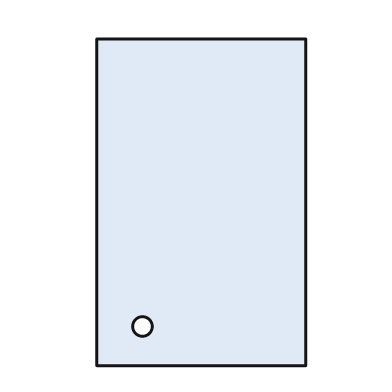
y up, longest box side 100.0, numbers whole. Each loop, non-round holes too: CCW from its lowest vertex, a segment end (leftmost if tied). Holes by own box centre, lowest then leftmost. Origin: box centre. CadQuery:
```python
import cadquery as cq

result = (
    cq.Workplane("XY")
    .moveTo(-32.0, -50.0)
    .lineTo(32.0, -50.0)
    .lineTo(32.0, 50.0)
    .lineTo(-32.0, 50.0)
    .close()
    .moveTo(-18.0, -38.0)
    .circle(3.0)
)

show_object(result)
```